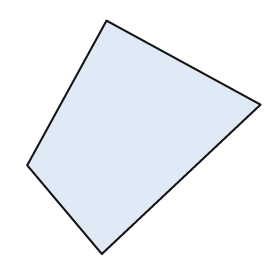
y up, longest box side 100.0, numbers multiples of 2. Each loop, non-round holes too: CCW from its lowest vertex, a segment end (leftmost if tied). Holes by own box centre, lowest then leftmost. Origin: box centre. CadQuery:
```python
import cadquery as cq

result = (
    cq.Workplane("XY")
    .moveTo(-18.0, -50.0)
    .lineTo(50.0, 14.0)
    .lineTo(-16.0, 50.0)
    .lineTo(-50.0, -12.0)
    .close()
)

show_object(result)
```